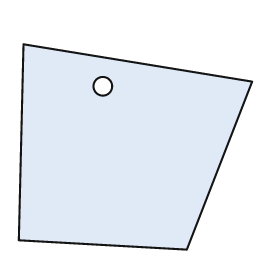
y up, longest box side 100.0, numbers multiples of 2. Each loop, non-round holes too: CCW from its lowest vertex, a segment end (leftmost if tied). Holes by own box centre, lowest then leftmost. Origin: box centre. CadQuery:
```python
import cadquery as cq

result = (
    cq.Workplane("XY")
    .moveTo(22.0, -44.0)
    .lineTo(50.0, 28.0)
    .lineTo(-48.0, 44.0)
    .lineTo(-50.0, -40.0)
    .close()
    .moveTo(-14.0, 26.0)
    .circle(4.0)
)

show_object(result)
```